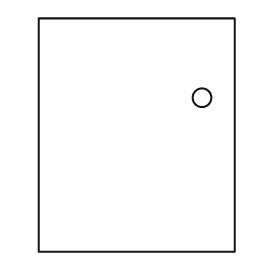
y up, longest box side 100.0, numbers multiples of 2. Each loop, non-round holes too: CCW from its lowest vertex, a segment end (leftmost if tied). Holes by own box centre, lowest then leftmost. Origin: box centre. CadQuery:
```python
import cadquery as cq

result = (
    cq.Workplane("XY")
    .moveTo(-42.0, -50.0)
    .lineTo(42.0, -50.0)
    .lineTo(42.0, 50.0)
    .lineTo(-42.0, 50.0)
    .close()
    .moveTo(28.0, 16.0)
    .circle(4.0)
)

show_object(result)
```